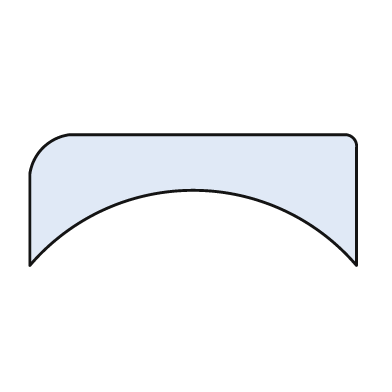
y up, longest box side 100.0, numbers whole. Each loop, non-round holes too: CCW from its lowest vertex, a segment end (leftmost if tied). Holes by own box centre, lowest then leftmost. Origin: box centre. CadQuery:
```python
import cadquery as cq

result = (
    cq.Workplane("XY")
    .moveTo(-50.0, -20.0)
    .threePointArc((0.0, 3.0), (50.0, -20.0))
    .lineTo(50.0, 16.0)
    .threePointArc((49.0, 19.0), (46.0, 20.0))
    .lineTo(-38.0, 20.0)
    .threePointArc((-46.0, 16.0), (-50.0, 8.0))
    .close()
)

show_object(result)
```